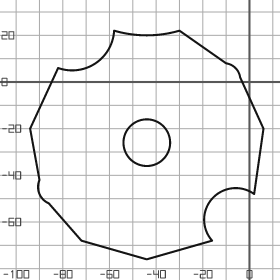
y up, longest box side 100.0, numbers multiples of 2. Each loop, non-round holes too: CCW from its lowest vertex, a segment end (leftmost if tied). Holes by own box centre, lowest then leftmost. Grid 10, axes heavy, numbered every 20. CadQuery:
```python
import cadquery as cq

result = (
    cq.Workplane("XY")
    .moveTo(-44.0, -76.0)
    .lineTo(-16.0, -68.0)
    .threePointArc((-16.0, -50.0), (2.0, -48.0))
    .lineTo(6.0, -20.0)
    .lineTo(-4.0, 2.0)
    .threePointArc((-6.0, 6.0), (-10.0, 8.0))
    .lineTo(-30.0, 22.0)
    .threePointArc((-44.0, 20.0), (-58.0, 22.0))
    .threePointArc((-66.0, 8.0), (-82.0, 6.0))
    .lineTo(-94.0, -20.0)
    .lineTo(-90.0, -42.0)
    .threePointArc((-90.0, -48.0), (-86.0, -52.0))
    .lineTo(-72.0, -68.0)
    .close()
    .moveTo(-44.0, -26.0)
    .circle(10.0)
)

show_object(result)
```